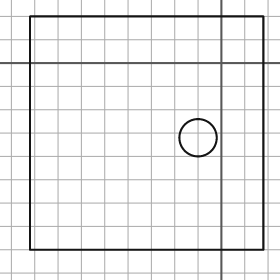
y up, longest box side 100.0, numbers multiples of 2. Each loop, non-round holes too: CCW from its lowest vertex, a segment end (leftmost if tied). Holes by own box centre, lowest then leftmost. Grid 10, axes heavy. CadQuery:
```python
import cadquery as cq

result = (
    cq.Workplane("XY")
    .moveTo(-82.0, -80.0)
    .lineTo(18.0, -80.0)
    .lineTo(18.0, 20.0)
    .lineTo(-82.0, 20.0)
    .close()
    .moveTo(-10.0, -32.0)
    .circle(8.0)
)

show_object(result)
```